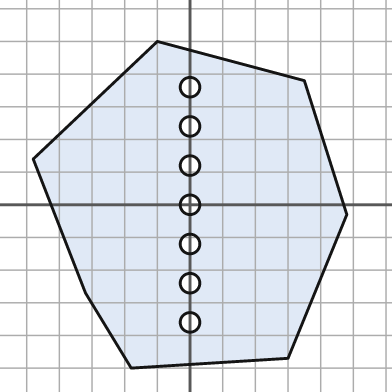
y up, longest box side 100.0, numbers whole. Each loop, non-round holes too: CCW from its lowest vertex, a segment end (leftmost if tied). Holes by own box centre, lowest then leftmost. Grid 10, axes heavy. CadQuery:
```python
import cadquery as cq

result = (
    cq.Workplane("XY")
    .moveTo(-18.0, -50.0)
    .lineTo(30.0, -47.0)
    .lineTo(48.0, -3.0)
    .lineTo(35.0, 38.0)
    .lineTo(-10.0, 50.0)
    .lineTo(-48.0, 14.0)
    .lineTo(-32.0, -27.0)
    .close()
    .moveTo(0.0, -36.0)
    .circle(3.0)
    .moveTo(0.0, -24.0)
    .circle(3.0)
    .moveTo(0.0, -12.0)
    .circle(3.0)
    .moveTo(0.0, 0.0)
    .circle(3.0)
    .moveTo(0.0, 12.0)
    .circle(3.0)
    .moveTo(0.0, 24.0)
    .circle(3.0)
    .moveTo(0.0, 36.0)
    .circle(3.0)
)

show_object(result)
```